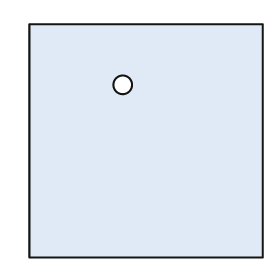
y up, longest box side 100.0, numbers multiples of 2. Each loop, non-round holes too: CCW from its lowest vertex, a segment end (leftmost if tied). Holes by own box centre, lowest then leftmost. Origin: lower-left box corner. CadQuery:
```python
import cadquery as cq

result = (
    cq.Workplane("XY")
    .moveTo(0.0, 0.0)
    .lineTo(100.0, 0.0)
    .lineTo(100.0, 100.0)
    .lineTo(0.0, 100.0)
    .close()
    .moveTo(40.0, 74.0)
    .circle(4.0)
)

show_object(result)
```